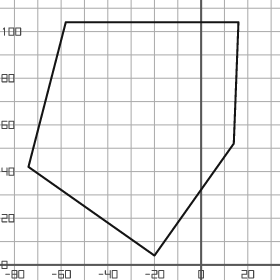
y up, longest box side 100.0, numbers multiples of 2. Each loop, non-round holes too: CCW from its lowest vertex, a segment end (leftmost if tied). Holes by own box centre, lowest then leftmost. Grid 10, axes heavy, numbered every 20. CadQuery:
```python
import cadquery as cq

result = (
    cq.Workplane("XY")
    .moveTo(-20.0, 4.0)
    .lineTo(14.0, 52.0)
    .lineTo(16.0, 104.0)
    .lineTo(-58.0, 104.0)
    .lineTo(-74.0, 42.0)
    .close()
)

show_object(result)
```